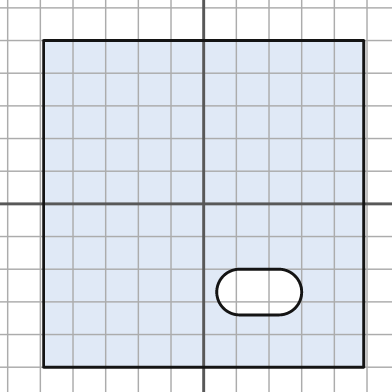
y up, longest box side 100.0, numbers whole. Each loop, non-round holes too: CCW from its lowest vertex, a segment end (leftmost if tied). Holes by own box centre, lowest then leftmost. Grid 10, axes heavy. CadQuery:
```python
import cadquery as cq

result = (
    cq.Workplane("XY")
    .moveTo(-49.0, -50.0)
    .lineTo(49.0, -50.0)
    .lineTo(49.0, 50.0)
    .lineTo(-49.0, 50.0)
    .close()
    .moveTo(11.0, -34.0)
    .lineTo(23.0, -34.0)
    .threePointArc((30.0, -27.0), (23.0, -20.0))
    .lineTo(11.0, -20.0)
    .threePointArc((4.0, -27.0), (11.0, -34.0))
    .close()
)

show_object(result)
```